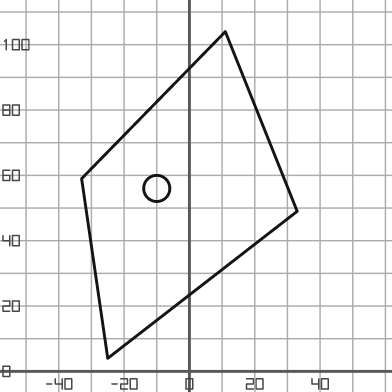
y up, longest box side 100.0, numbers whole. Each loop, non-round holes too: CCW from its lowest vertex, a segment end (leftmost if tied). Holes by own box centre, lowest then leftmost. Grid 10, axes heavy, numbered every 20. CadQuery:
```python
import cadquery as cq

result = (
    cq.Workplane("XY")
    .moveTo(-25.0, 4.0)
    .lineTo(33.0, 49.0)
    .lineTo(11.0, 104.0)
    .lineTo(-33.0, 59.0)
    .close()
    .moveTo(-10.0, 56.0)
    .circle(4.0)
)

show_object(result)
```